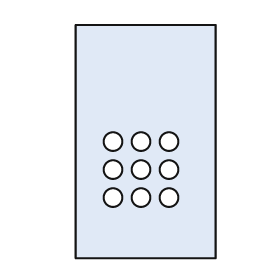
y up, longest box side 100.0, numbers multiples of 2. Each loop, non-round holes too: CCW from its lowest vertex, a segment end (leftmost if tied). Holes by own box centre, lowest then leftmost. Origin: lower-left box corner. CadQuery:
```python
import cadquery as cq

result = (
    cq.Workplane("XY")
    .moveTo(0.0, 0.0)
    .lineTo(60.0, 0.0)
    .lineTo(60.0, 100.0)
    .lineTo(0.0, 100.0)
    .close()
    .moveTo(16.0, 26.0)
    .circle(4.0)
    .moveTo(28.0, 26.0)
    .circle(4.0)
    .moveTo(40.0, 26.0)
    .circle(4.0)
    .moveTo(16.0, 38.0)
    .circle(4.0)
    .moveTo(28.0, 38.0)
    .circle(4.0)
    .moveTo(40.0, 38.0)
    .circle(4.0)
    .moveTo(16.0, 50.0)
    .circle(4.0)
    .moveTo(28.0, 50.0)
    .circle(4.0)
    .moveTo(40.0, 50.0)
    .circle(4.0)
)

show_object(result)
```